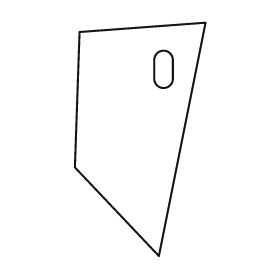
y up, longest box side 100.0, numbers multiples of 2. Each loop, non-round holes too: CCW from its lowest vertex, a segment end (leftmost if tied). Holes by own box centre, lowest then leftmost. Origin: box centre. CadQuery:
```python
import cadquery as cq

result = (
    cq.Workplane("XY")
    .moveTo(8.0, -50.0)
    .lineTo(28.0, 50.0)
    .lineTo(-26.0, 46.0)
    .lineTo(-28.0, -12.0)
    .close()
    .moveTo(6.0, 26.0)
    .threePointArc((10.0, 22.0), (14.0, 26.0))
    .lineTo(14.0, 34.0)
    .threePointArc((10.0, 38.0), (6.0, 34.0))
    .close()
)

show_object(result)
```